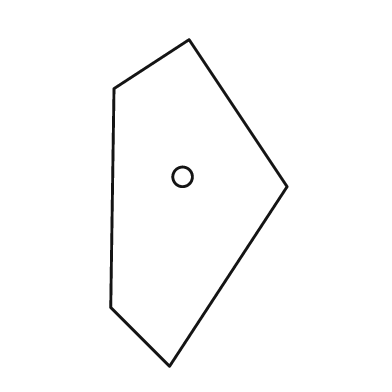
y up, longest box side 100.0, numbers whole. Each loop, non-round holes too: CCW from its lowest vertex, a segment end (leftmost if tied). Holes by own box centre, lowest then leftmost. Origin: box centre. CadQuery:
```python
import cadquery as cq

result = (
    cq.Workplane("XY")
    .moveTo(-9.0, -50.0)
    .lineTo(27.0, 5.0)
    .lineTo(-3.0, 50.0)
    .lineTo(-26.0, 35.0)
    .lineTo(-27.0, -32.0)
    .close()
    .moveTo(-5.0, 8.0)
    .circle(3.0)
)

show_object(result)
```